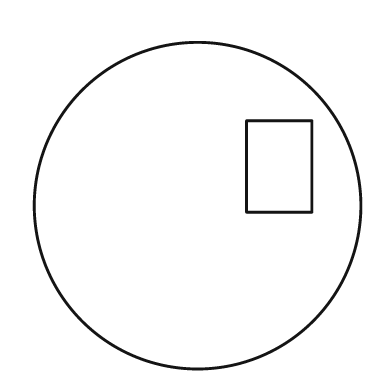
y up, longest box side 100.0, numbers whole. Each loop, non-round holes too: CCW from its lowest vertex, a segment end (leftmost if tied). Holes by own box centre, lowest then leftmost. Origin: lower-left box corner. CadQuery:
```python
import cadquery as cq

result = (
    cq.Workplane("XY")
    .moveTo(50.0, 50.0)
    .circle(50.0)
    .moveTo(65.0, 48.0)
    .lineTo(85.0, 48.0)
    .lineTo(85.0, 76.0)
    .lineTo(65.0, 76.0)
    .close()
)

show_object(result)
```